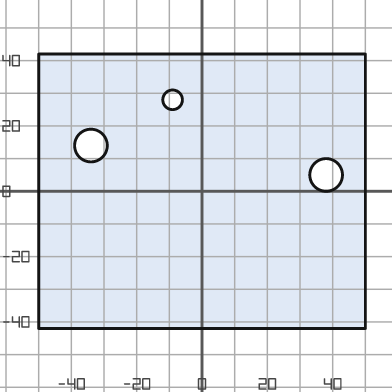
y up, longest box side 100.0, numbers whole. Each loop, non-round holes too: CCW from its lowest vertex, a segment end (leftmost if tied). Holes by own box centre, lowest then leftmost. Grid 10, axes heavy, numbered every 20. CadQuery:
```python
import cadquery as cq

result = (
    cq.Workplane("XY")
    .moveTo(-50.0, -42.0)
    .lineTo(50.0, -42.0)
    .lineTo(50.0, 42.0)
    .lineTo(-50.0, 42.0)
    .close()
    .moveTo(38.0, 5.0)
    .circle(5.0)
    .moveTo(-34.0, 14.0)
    .circle(5.0)
    .moveTo(-9.0, 28.0)
    .circle(3.0)
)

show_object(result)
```